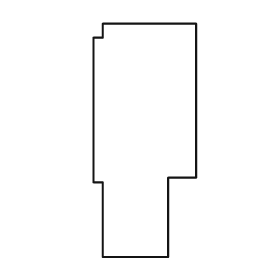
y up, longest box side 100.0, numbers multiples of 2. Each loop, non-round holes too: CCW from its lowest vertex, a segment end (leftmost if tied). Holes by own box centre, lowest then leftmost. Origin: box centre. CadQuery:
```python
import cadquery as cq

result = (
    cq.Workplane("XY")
    .moveTo(-18.0, -50.0)
    .lineTo(10.0, -50.0)
    .lineTo(10.0, -16.0)
    .lineTo(22.0, -16.0)
    .lineTo(22.0, 50.0)
    .lineTo(-18.0, 50.0)
    .lineTo(-18.0, 44.0)
    .lineTo(-22.0, 44.0)
    .lineTo(-22.0, -18.0)
    .lineTo(-18.0, -18.0)
    .close()
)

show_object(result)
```